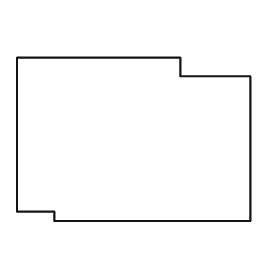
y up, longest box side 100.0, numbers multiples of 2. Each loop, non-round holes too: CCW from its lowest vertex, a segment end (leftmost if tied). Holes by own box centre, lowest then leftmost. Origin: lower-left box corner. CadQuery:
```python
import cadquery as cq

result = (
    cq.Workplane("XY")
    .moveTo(16.0, 0.0)
    .lineTo(100.0, 0.0)
    .lineTo(100.0, 62.0)
    .lineTo(70.0, 62.0)
    .lineTo(70.0, 70.0)
    .lineTo(0.0, 70.0)
    .lineTo(0.0, 4.0)
    .lineTo(16.0, 4.0)
    .close()
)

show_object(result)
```